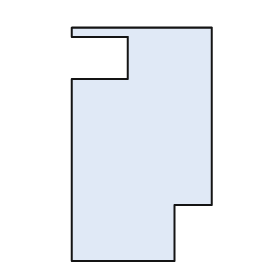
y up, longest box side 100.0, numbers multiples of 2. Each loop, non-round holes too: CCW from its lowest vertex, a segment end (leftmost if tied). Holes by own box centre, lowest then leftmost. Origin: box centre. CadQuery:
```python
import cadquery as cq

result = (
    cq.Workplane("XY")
    .moveTo(-30.0, -50.0)
    .lineTo(14.0, -50.0)
    .lineTo(14.0, -26.0)
    .lineTo(30.0, -26.0)
    .lineTo(30.0, 50.0)
    .lineTo(-30.0, 50.0)
    .lineTo(-30.0, 46.0)
    .lineTo(-6.0, 46.0)
    .lineTo(-6.0, 28.0)
    .lineTo(-30.0, 28.0)
    .close()
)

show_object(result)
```